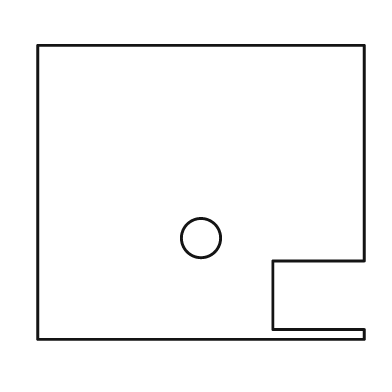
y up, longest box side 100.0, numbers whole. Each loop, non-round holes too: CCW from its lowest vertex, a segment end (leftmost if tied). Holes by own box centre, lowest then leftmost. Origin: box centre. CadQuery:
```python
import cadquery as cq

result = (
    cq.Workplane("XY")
    .moveTo(-50.0, -45.0)
    .lineTo(50.0, -45.0)
    .lineTo(50.0, -42.0)
    .lineTo(22.0, -42.0)
    .lineTo(22.0, -21.0)
    .lineTo(50.0, -21.0)
    .lineTo(50.0, 45.0)
    .lineTo(-50.0, 45.0)
    .close()
    .moveTo(0.0, -14.0)
    .circle(6.0)
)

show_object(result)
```